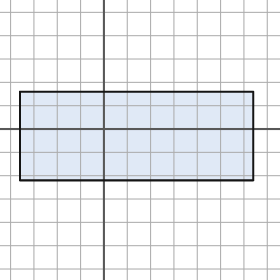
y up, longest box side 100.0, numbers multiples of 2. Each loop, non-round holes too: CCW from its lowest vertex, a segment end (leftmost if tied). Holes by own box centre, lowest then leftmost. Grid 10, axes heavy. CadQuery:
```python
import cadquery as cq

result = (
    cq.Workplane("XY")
    .moveTo(-36.0, -22.0)
    .lineTo(64.0, -22.0)
    .lineTo(64.0, 16.0)
    .lineTo(-36.0, 16.0)
    .close()
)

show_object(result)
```